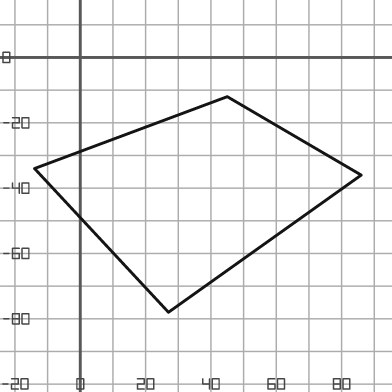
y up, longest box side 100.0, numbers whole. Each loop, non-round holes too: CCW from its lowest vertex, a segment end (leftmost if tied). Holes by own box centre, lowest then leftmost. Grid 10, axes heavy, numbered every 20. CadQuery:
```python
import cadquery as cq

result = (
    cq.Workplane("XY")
    .moveTo(27.0, -78.0)
    .lineTo(86.0, -36.0)
    .lineTo(45.0, -12.0)
    .lineTo(-14.0, -34.0)
    .close()
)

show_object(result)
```